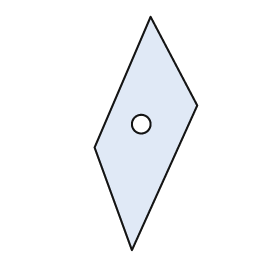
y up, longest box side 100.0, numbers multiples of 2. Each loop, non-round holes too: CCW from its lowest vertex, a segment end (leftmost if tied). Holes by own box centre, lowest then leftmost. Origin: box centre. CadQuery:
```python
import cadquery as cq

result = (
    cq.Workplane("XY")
    .moveTo(-6.0, -50.0)
    .lineTo(22.0, 12.0)
    .lineTo(2.0, 50.0)
    .lineTo(-22.0, -6.0)
    .close()
    .moveTo(-2.0, 4.0)
    .circle(4.0)
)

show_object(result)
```